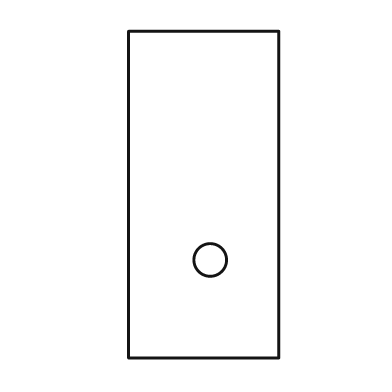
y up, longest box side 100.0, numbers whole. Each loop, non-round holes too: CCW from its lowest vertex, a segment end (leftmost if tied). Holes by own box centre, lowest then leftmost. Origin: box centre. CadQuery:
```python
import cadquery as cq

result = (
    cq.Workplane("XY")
    .moveTo(-23.0, -50.0)
    .lineTo(23.0, -50.0)
    .lineTo(23.0, 50.0)
    .lineTo(-23.0, 50.0)
    .close()
    .moveTo(2.0, -20.0)
    .circle(5.0)
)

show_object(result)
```